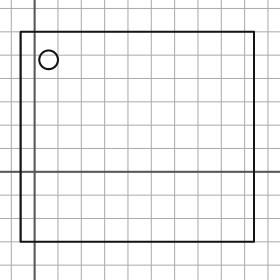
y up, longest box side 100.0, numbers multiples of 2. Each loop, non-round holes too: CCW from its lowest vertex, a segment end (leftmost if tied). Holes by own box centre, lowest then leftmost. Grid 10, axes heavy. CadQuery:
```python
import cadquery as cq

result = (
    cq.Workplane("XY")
    .moveTo(-6.0, -30.0)
    .lineTo(94.0, -30.0)
    .lineTo(94.0, 60.0)
    .lineTo(-6.0, 60.0)
    .close()
    .moveTo(6.0, 48.0)
    .circle(4.0)
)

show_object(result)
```